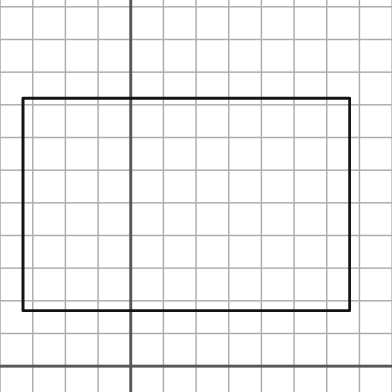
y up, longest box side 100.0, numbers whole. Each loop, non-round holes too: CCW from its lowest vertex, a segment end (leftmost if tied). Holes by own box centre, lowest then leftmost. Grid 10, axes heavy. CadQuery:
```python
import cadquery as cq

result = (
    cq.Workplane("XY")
    .moveTo(-33.0, 17.0)
    .lineTo(67.0, 17.0)
    .lineTo(67.0, 82.0)
    .lineTo(-33.0, 82.0)
    .close()
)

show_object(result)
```